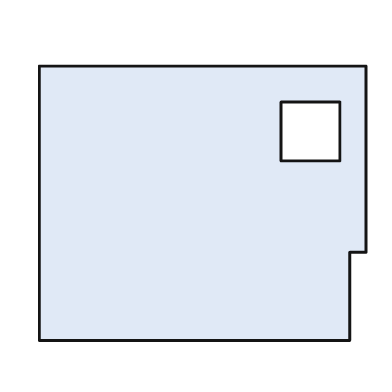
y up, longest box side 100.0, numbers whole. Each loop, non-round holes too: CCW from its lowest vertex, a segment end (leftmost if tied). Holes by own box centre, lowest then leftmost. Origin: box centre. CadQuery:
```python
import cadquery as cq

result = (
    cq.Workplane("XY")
    .moveTo(-50.0, -42.0)
    .lineTo(45.0, -42.0)
    .lineTo(45.0, -15.0)
    .lineTo(50.0, -15.0)
    .lineTo(50.0, 42.0)
    .lineTo(-50.0, 42.0)
    .close()
    .moveTo(24.0, 13.0)
    .lineTo(42.0, 13.0)
    .lineTo(42.0, 31.0)
    .lineTo(24.0, 31.0)
    .close()
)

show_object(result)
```